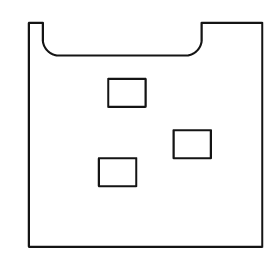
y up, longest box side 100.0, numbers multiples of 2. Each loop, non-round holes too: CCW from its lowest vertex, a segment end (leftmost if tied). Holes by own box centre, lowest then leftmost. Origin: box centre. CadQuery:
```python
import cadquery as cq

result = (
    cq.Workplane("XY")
    .moveTo(-50.0, -48.0)
    .lineTo(50.0, -48.0)
    .lineTo(50.0, 48.0)
    .lineTo(24.0, 48.0)
    .lineTo(24.0, 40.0)
    .threePointArc((22.0, 36.0), (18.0, 34.0))
    .lineTo(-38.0, 34.0)
    .threePointArc((-42.0, 36.0), (-44.0, 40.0))
    .lineTo(-44.0, 48.0)
    .lineTo(-50.0, 48.0)
    .close()
    .moveTo(-20.0, -22.0)
    .lineTo(-4.0, -22.0)
    .lineTo(-4.0, -10.0)
    .lineTo(-20.0, -10.0)
    .close()
    .moveTo(12.0, -10.0)
    .lineTo(28.0, -10.0)
    .lineTo(28.0, 2.0)
    .lineTo(12.0, 2.0)
    .close()
    .moveTo(-16.0, 12.0)
    .lineTo(0.0, 12.0)
    .lineTo(0.0, 24.0)
    .lineTo(-16.0, 24.0)
    .close()
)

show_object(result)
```